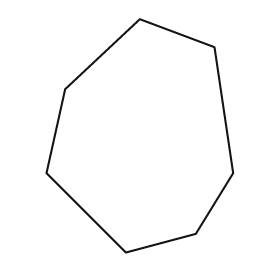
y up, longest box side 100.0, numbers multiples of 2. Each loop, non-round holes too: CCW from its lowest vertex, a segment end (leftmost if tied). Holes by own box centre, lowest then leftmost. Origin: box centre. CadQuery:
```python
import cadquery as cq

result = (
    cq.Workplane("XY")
    .moveTo(-6.0, -50.0)
    .lineTo(24.0, -42.0)
    .lineTo(40.0, -16.0)
    .lineTo(32.0, 38.0)
    .lineTo(0.0, 50.0)
    .lineTo(-32.0, 20.0)
    .lineTo(-40.0, -16.0)
    .close()
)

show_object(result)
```